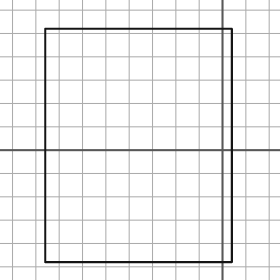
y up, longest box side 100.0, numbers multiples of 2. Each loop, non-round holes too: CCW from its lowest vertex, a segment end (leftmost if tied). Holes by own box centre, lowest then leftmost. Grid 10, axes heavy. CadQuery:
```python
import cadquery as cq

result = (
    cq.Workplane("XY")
    .moveTo(-76.0, -48.0)
    .lineTo(4.0, -48.0)
    .lineTo(4.0, 52.0)
    .lineTo(-76.0, 52.0)
    .close()
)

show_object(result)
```